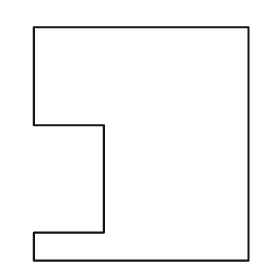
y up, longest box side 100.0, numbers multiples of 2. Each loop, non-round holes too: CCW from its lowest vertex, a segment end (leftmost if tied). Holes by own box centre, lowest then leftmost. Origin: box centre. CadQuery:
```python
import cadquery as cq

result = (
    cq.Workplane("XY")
    .moveTo(-46.0, -50.0)
    .lineTo(46.0, -50.0)
    .lineTo(46.0, 50.0)
    .lineTo(-46.0, 50.0)
    .lineTo(-46.0, 8.0)
    .lineTo(-16.0, 8.0)
    .lineTo(-16.0, -38.0)
    .lineTo(-46.0, -38.0)
    .close()
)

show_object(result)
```